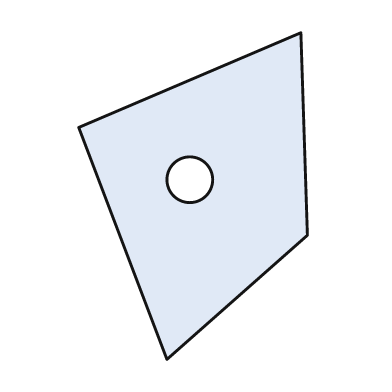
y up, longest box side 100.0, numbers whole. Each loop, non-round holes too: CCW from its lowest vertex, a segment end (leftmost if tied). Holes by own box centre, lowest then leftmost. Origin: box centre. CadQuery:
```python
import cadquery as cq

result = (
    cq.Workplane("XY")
    .moveTo(-8.0, -50.0)
    .lineTo(35.0, -12.0)
    .lineTo(33.0, 50.0)
    .lineTo(-35.0, 21.0)
    .close()
    .moveTo(-1.0, 5.0)
    .circle(7.0)
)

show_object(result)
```